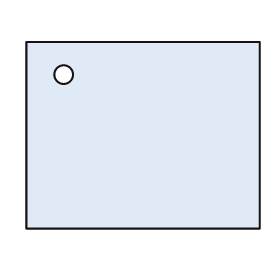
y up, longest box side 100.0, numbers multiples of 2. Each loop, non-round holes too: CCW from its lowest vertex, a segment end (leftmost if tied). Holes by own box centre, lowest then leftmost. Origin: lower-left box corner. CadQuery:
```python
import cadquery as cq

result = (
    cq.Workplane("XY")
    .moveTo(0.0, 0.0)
    .lineTo(100.0, 0.0)
    .lineTo(100.0, 80.0)
    .lineTo(0.0, 80.0)
    .close()
    .moveTo(16.0, 66.0)
    .circle(4.0)
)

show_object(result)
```